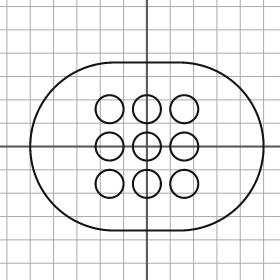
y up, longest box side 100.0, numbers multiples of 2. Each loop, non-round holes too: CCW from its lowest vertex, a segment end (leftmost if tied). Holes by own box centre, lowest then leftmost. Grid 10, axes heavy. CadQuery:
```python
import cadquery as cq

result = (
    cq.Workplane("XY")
    .moveTo(-14.0, -36.0)
    .lineTo(14.0, -36.0)
    .threePointArc((50.0, 0.0), (14.0, 36.0))
    .lineTo(-14.0, 36.0)
    .threePointArc((-50.0, 0.0), (-14.0, -36.0))
    .close()
    .moveTo(-16.0, -16.0)
    .circle(6.0)
    .moveTo(0.0, -16.0)
    .circle(6.0)
    .moveTo(16.0, -16.0)
    .circle(6.0)
    .moveTo(-16.0, 0.0)
    .circle(6.0)
    .moveTo(0.0, 0.0)
    .circle(6.0)
    .moveTo(16.0, 0.0)
    .circle(6.0)
    .moveTo(-16.0, 16.0)
    .circle(6.0)
    .moveTo(0.0, 16.0)
    .circle(6.0)
    .moveTo(16.0, 16.0)
    .circle(6.0)
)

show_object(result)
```